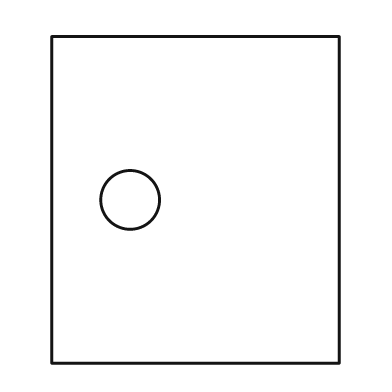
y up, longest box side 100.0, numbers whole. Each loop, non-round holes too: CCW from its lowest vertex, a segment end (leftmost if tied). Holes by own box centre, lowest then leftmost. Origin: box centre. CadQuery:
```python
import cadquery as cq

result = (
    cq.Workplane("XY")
    .moveTo(-44.0, -50.0)
    .lineTo(44.0, -50.0)
    .lineTo(44.0, 50.0)
    .lineTo(-44.0, 50.0)
    .close()
    .moveTo(-20.0, 0.0)
    .circle(9.0)
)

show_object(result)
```